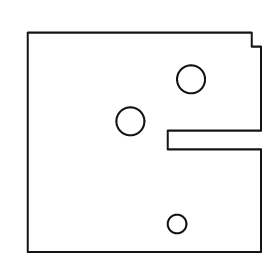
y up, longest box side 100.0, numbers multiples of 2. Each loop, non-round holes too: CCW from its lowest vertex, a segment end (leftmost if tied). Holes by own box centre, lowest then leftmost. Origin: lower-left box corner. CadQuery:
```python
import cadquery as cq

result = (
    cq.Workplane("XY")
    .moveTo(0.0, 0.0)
    .lineTo(100.0, 0.0)
    .lineTo(100.0, 44.0)
    .lineTo(60.0, 44.0)
    .lineTo(60.0, 52.0)
    .lineTo(100.0, 52.0)
    .lineTo(100.0, 88.0)
    .lineTo(96.0, 88.0)
    .lineTo(96.0, 94.0)
    .lineTo(0.0, 94.0)
    .close()
    .moveTo(64.0, 12.0)
    .circle(4.0)
    .moveTo(44.0, 56.0)
    .circle(6.0)
    .moveTo(70.0, 74.0)
    .circle(6.0)
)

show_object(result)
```